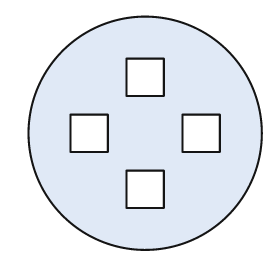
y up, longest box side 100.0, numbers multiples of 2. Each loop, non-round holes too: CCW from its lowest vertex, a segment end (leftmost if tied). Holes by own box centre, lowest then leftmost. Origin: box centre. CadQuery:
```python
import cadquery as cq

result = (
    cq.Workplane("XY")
    .moveTo(0.0, 0.0)
    .circle(50.0)
    .moveTo(-8.0, -32.0)
    .lineTo(8.0, -32.0)
    .lineTo(8.0, -16.0)
    .lineTo(-8.0, -16.0)
    .close()
    .moveTo(-32.0, -8.0)
    .lineTo(-16.0, -8.0)
    .lineTo(-16.0, 8.0)
    .lineTo(-32.0, 8.0)
    .close()
    .moveTo(16.0, -8.0)
    .lineTo(32.0, -8.0)
    .lineTo(32.0, 8.0)
    .lineTo(16.0, 8.0)
    .close()
    .moveTo(-8.0, 16.0)
    .lineTo(8.0, 16.0)
    .lineTo(8.0, 32.0)
    .lineTo(-8.0, 32.0)
    .close()
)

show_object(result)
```